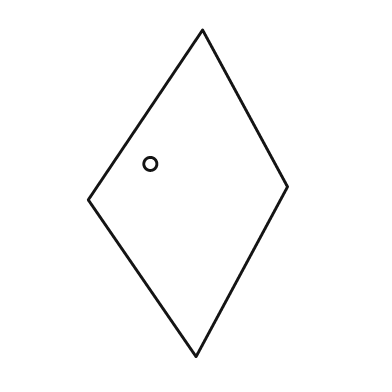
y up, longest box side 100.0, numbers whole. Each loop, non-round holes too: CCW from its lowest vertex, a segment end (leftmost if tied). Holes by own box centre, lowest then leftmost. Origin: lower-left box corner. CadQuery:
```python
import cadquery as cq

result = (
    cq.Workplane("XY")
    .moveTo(33.0, 0.0)
    .lineTo(61.0, 52.0)
    .lineTo(35.0, 100.0)
    .lineTo(0.0, 48.0)
    .close()
    .moveTo(19.0, 59.0)
    .circle(2.0)
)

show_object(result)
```